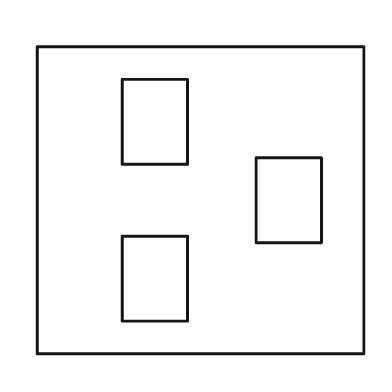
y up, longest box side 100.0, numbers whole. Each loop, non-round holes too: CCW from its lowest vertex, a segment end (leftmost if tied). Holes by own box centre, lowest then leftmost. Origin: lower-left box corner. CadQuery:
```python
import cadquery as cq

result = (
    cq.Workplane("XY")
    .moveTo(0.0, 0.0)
    .lineTo(100.0, 0.0)
    .lineTo(100.0, 94.0)
    .lineTo(0.0, 94.0)
    .close()
    .moveTo(26.0, 10.0)
    .lineTo(46.0, 10.0)
    .lineTo(46.0, 36.0)
    .lineTo(26.0, 36.0)
    .close()
    .moveTo(67.0, 34.0)
    .lineTo(87.0, 34.0)
    .lineTo(87.0, 60.0)
    .lineTo(67.0, 60.0)
    .close()
    .moveTo(26.0, 58.0)
    .lineTo(46.0, 58.0)
    .lineTo(46.0, 84.0)
    .lineTo(26.0, 84.0)
    .close()
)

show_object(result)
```